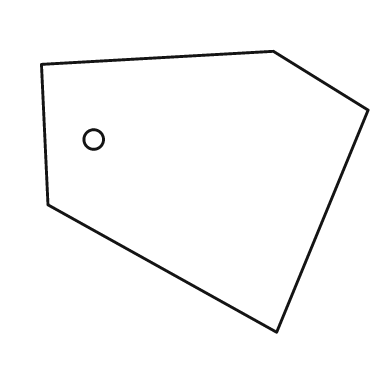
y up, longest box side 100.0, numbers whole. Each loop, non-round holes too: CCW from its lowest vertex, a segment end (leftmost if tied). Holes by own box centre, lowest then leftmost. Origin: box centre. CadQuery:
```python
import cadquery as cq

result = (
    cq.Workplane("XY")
    .moveTo(22.0, -43.0)
    .lineTo(50.0, 25.0)
    .lineTo(21.0, 43.0)
    .lineTo(-50.0, 39.0)
    .lineTo(-48.0, -4.0)
    .close()
    .moveTo(-34.0, 16.0)
    .circle(3.0)
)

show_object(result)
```